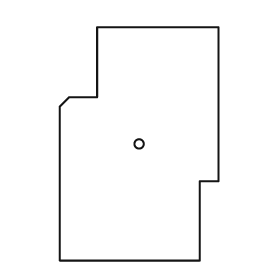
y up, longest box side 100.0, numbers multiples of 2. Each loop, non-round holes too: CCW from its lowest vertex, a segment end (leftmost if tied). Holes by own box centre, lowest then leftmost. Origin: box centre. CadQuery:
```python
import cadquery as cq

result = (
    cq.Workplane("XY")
    .moveTo(-34.0, -50.0)
    .lineTo(26.0, -50.0)
    .lineTo(26.0, -16.0)
    .lineTo(34.0, -16.0)
    .lineTo(34.0, 50.0)
    .lineTo(-18.0, 50.0)
    .lineTo(-18.0, 20.0)
    .lineTo(-30.0, 20.0)
    .lineTo(-34.0, 16.0)
    .close()
    .moveTo(0.0, 0.0)
    .circle(2.0)
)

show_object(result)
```